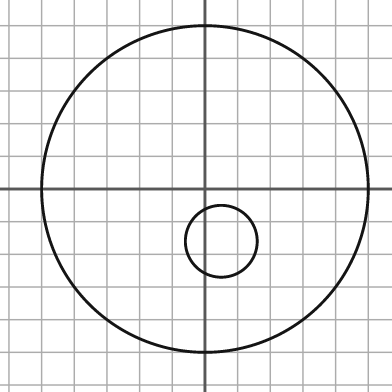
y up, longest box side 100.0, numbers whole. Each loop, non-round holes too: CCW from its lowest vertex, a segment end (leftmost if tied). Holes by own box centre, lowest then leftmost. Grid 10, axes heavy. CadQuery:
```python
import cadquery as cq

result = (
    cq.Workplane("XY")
    .moveTo(0.0, 0.0)
    .circle(50.0)
    .moveTo(5.0, -16.0)
    .circle(11.0)
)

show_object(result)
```